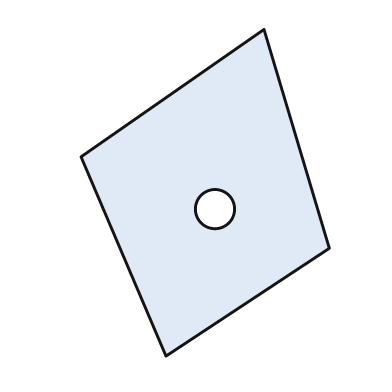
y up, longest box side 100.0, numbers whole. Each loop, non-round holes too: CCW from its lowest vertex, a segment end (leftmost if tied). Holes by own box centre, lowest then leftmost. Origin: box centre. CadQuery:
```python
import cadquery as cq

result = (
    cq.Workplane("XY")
    .moveTo(-12.0, -50.0)
    .lineTo(38.0, -17.0)
    .lineTo(18.0, 50.0)
    .lineTo(-38.0, 11.0)
    .close()
    .moveTo(3.0, -5.0)
    .circle(6.0)
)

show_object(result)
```